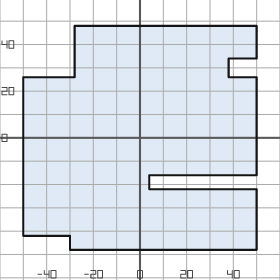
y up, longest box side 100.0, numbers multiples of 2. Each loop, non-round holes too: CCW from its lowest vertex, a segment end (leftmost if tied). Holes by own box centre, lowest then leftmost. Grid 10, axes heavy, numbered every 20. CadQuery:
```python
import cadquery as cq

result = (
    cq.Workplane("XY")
    .moveTo(-30.0, -48.0)
    .lineTo(50.0, -48.0)
    .lineTo(50.0, -22.0)
    .lineTo(4.0, -22.0)
    .lineTo(4.0, -16.0)
    .lineTo(50.0, -16.0)
    .lineTo(50.0, 26.0)
    .lineTo(38.0, 26.0)
    .lineTo(38.0, 34.0)
    .lineTo(50.0, 34.0)
    .lineTo(50.0, 48.0)
    .lineTo(-28.0, 48.0)
    .lineTo(-28.0, 26.0)
    .lineTo(-50.0, 26.0)
    .lineTo(-50.0, -42.0)
    .lineTo(-30.0, -42.0)
    .close()
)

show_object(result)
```